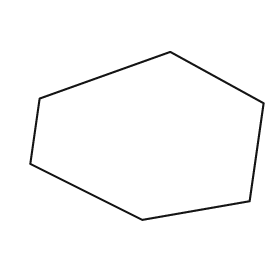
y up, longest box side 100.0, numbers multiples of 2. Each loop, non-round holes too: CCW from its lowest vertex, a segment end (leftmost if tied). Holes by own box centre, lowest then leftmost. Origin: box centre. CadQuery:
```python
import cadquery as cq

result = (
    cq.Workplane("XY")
    .moveTo(-2.0, -36.0)
    .lineTo(44.0, -28.0)
    .lineTo(50.0, 14.0)
    .lineTo(10.0, 36.0)
    .lineTo(-46.0, 16.0)
    .lineTo(-50.0, -12.0)
    .close()
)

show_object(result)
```